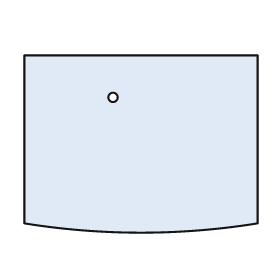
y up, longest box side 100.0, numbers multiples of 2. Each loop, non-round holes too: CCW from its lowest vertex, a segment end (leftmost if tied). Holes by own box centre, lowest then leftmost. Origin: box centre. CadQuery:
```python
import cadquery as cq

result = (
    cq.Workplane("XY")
    .moveTo(-50.0, -34.0)
    .threePointArc((0.0, -38.0), (50.0, -34.0))
    .lineTo(50.0, 38.0)
    .lineTo(-50.0, 38.0)
    .close()
    .moveTo(-12.0, 20.0)
    .circle(2.0)
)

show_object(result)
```